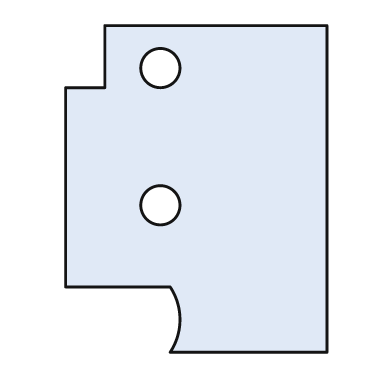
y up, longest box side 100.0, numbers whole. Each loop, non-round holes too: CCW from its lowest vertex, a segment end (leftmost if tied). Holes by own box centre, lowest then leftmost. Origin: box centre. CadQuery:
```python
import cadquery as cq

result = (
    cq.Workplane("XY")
    .moveTo(-8.0, -50.0)
    .lineTo(40.0, -50.0)
    .lineTo(40.0, 50.0)
    .lineTo(-28.0, 50.0)
    .lineTo(-28.0, 31.0)
    .lineTo(-40.0, 31.0)
    .lineTo(-40.0, -30.0)
    .lineTo(-8.0, -30.0)
    .threePointArc((-5.0, -40.0), (-8.0, -50.0))
    .close()
    .moveTo(-11.0, -5.0)
    .circle(6.0)
    .moveTo(-11.0, 37.0)
    .circle(6.0)
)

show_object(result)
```